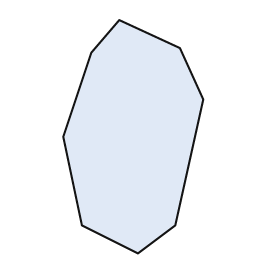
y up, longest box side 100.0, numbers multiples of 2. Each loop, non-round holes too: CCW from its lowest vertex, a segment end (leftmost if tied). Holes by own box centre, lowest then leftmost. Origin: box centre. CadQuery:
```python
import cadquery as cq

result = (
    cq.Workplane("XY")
    .moveTo(2.0, -50.0)
    .lineTo(18.0, -38.0)
    .lineTo(30.0, 16.0)
    .lineTo(20.0, 38.0)
    .lineTo(-6.0, 50.0)
    .lineTo(-18.0, 36.0)
    .lineTo(-30.0, 0.0)
    .lineTo(-22.0, -38.0)
    .close()
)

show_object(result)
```